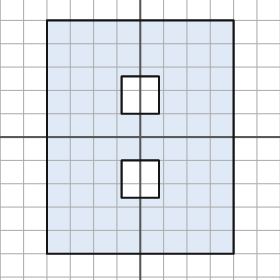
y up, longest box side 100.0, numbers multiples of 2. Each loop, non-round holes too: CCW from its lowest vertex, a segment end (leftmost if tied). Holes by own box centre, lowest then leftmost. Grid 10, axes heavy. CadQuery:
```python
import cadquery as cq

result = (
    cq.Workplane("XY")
    .moveTo(-40.0, -50.0)
    .lineTo(40.0, -50.0)
    .lineTo(40.0, 50.0)
    .lineTo(-40.0, 50.0)
    .close()
    .moveTo(-8.0, -26.0)
    .lineTo(8.0, -26.0)
    .lineTo(8.0, -10.0)
    .lineTo(-8.0, -10.0)
    .close()
    .moveTo(-8.0, 10.0)
    .lineTo(8.0, 10.0)
    .lineTo(8.0, 26.0)
    .lineTo(-8.0, 26.0)
    .close()
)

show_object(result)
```